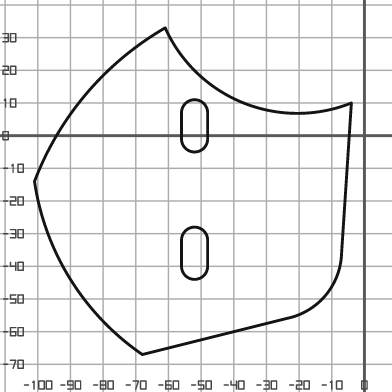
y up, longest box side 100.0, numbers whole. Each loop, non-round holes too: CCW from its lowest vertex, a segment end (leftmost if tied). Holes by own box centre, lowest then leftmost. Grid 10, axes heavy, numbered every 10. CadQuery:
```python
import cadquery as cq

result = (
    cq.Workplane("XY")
    .moveTo(-68.0, -67.0)
    .lineTo(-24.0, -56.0)
    .threePointArc((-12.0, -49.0), (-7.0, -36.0))
    .lineTo(-4.0, 10.0)
    .threePointArc((-37.0, 10.0), (-61.0, 33.0))
    .threePointArc((-85.0, 13.0), (-101.0, -14.0))
    .threePointArc((-90.0, -44.0), (-68.0, -67.0))
    .close()
    .moveTo(-56.0, -40.0)
    .threePointArc((-52.0, -44.0), (-48.0, -40.0))
    .lineTo(-48.0, -32.0)
    .threePointArc((-52.0, -28.0), (-56.0, -32.0))
    .close()
    .moveTo(-56.0, -1.0)
    .threePointArc((-52.0, -5.0), (-48.0, -1.0))
    .lineTo(-48.0, 7.0)
    .threePointArc((-52.0, 11.0), (-56.0, 7.0))
    .close()
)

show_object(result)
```